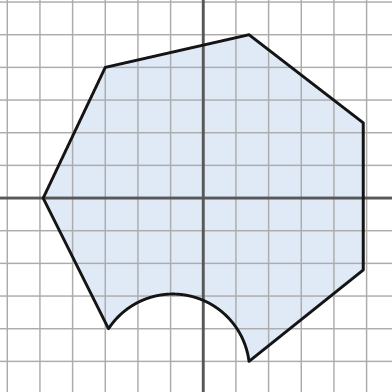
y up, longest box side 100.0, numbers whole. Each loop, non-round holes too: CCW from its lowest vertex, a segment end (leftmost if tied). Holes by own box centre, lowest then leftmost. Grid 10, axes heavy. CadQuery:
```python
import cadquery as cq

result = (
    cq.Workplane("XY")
    .moveTo(14.0, -50.0)
    .lineTo(49.0, -22.0)
    .lineTo(49.0, 23.0)
    .lineTo(14.0, 50.0)
    .lineTo(-30.0, 40.0)
    .lineTo(-49.0, 0.0)
    .lineTo(-29.0, -40.0)
    .threePointArc((-4.0, -30.0), (14.0, -50.0))
    .close()
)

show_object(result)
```